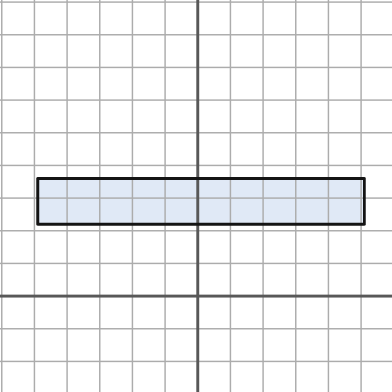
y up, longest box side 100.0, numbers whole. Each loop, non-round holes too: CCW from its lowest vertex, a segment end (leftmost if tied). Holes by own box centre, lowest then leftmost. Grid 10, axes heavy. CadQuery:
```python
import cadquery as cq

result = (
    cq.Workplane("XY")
    .moveTo(-49.0, 22.0)
    .lineTo(51.0, 22.0)
    .lineTo(51.0, 36.0)
    .lineTo(-49.0, 36.0)
    .close()
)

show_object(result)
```